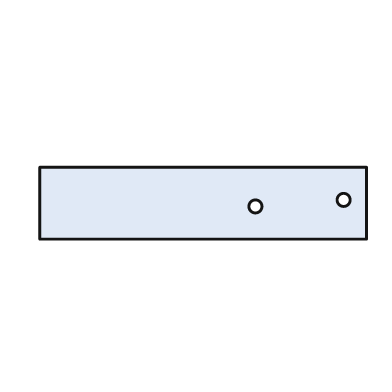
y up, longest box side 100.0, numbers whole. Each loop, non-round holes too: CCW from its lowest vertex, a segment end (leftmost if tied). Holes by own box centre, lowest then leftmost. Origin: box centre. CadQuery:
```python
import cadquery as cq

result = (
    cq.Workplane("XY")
    .moveTo(-50.0, -11.0)
    .lineTo(50.0, -11.0)
    .lineTo(50.0, 11.0)
    .lineTo(-50.0, 11.0)
    .close()
    .moveTo(16.0, -1.0)
    .circle(2.0)
    .moveTo(43.0, 1.0)
    .circle(2.0)
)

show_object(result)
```